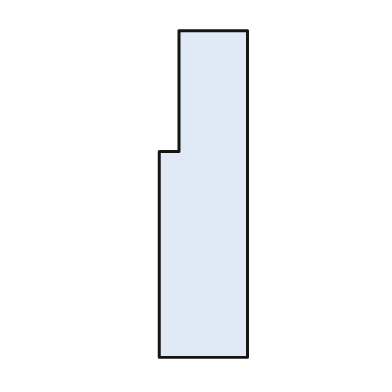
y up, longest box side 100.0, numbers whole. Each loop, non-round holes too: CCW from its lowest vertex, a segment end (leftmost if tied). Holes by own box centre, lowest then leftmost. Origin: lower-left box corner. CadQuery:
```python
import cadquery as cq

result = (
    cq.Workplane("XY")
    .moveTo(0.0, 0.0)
    .lineTo(27.0, 0.0)
    .lineTo(27.0, 100.0)
    .lineTo(6.0, 100.0)
    .lineTo(6.0, 63.0)
    .lineTo(0.0, 63.0)
    .close()
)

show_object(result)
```